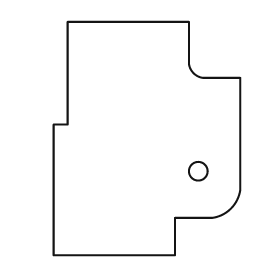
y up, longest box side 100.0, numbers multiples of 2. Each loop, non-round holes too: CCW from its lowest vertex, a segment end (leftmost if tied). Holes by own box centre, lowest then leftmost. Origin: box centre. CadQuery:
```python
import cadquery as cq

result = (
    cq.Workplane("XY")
    .moveTo(-40.0, -50.0)
    .lineTo(12.0, -50.0)
    .lineTo(12.0, -34.0)
    .lineTo(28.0, -34.0)
    .threePointArc((36.0, -30.0), (40.0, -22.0))
    .lineTo(40.0, 26.0)
    .lineTo(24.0, 26.0)
    .threePointArc((20.0, 28.0), (18.0, 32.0))
    .lineTo(18.0, 50.0)
    .lineTo(-34.0, 50.0)
    .lineTo(-34.0, 6.0)
    .lineTo(-40.0, 6.0)
    .close()
    .moveTo(22.0, -14.0)
    .circle(4.0)
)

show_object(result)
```